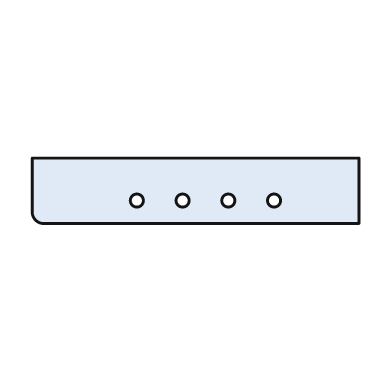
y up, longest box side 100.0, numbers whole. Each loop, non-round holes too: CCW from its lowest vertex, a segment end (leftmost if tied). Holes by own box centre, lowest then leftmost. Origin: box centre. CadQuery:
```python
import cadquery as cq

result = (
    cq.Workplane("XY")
    .moveTo(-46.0, -10.0)
    .lineTo(50.0, -10.0)
    .lineTo(50.0, 10.0)
    .lineTo(-50.0, 10.0)
    .lineTo(-50.0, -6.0)
    .threePointArc((-49.0, -9.0), (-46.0, -10.0))
    .close()
    .moveTo(-18.0, -3.0)
    .circle(2.0)
    .moveTo(-4.0, -3.0)
    .circle(2.0)
    .moveTo(10.0, -3.0)
    .circle(2.0)
    .moveTo(24.0, -3.0)
    .circle(2.0)
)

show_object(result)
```